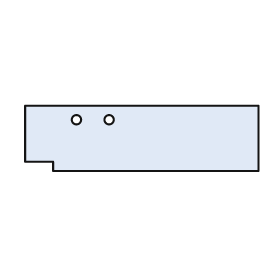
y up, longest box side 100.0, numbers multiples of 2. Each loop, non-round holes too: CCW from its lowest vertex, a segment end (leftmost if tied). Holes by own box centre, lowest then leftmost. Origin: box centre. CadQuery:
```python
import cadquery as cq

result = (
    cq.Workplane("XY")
    .moveTo(-38.0, -14.0)
    .lineTo(50.0, -14.0)
    .lineTo(50.0, 14.0)
    .lineTo(-50.0, 14.0)
    .lineTo(-50.0, -10.0)
    .lineTo(-38.0, -10.0)
    .close()
    .moveTo(-28.0, 8.0)
    .circle(2.0)
    .moveTo(-14.0, 8.0)
    .circle(2.0)
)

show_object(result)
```